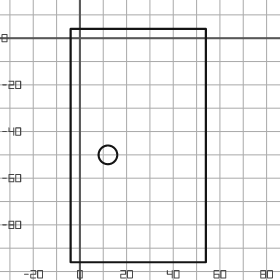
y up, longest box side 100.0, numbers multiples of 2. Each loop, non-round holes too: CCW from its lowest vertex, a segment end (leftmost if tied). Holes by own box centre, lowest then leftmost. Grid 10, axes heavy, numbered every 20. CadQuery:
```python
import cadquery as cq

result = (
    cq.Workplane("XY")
    .moveTo(-4.0, -96.0)
    .lineTo(54.0, -96.0)
    .lineTo(54.0, 4.0)
    .lineTo(-4.0, 4.0)
    .close()
    .moveTo(12.0, -50.0)
    .circle(4.0)
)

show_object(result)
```